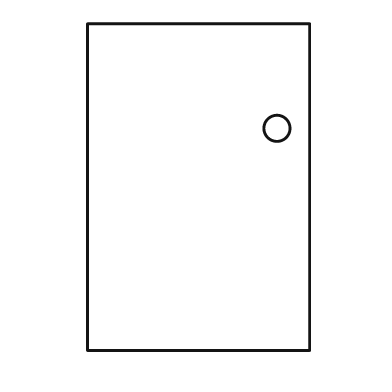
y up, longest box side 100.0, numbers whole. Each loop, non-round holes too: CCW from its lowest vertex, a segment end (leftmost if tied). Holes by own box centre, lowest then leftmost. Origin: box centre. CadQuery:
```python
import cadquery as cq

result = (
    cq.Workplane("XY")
    .moveTo(-34.0, -50.0)
    .lineTo(34.0, -50.0)
    .lineTo(34.0, 50.0)
    .lineTo(-34.0, 50.0)
    .close()
    .moveTo(24.0, 18.0)
    .circle(4.0)
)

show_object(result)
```